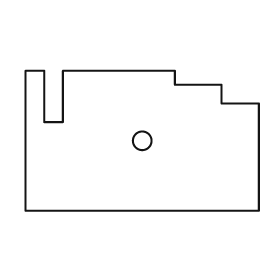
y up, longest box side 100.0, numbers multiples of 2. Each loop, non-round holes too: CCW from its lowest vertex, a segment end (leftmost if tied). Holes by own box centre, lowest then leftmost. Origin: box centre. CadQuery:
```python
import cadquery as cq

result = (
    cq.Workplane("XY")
    .moveTo(-50.0, -30.0)
    .lineTo(50.0, -30.0)
    .lineTo(50.0, 16.0)
    .lineTo(34.0, 16.0)
    .lineTo(34.0, 24.0)
    .lineTo(14.0, 24.0)
    .lineTo(14.0, 30.0)
    .lineTo(-34.0, 30.0)
    .lineTo(-34.0, 8.0)
    .lineTo(-42.0, 8.0)
    .lineTo(-42.0, 30.0)
    .lineTo(-50.0, 30.0)
    .close()
    .moveTo(0.0, 0.0)
    .circle(4.0)
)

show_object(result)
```